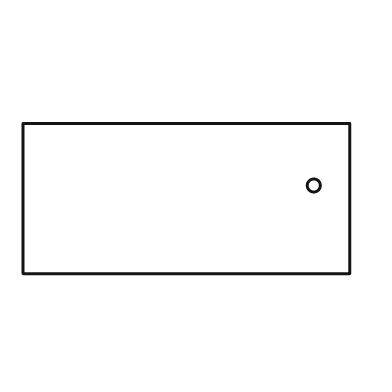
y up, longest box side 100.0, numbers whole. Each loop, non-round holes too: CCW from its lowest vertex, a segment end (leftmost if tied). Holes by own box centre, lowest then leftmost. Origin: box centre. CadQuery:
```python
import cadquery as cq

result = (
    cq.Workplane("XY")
    .moveTo(-50.0, -23.0)
    .lineTo(50.0, -23.0)
    .lineTo(50.0, 23.0)
    .lineTo(-50.0, 23.0)
    .close()
    .moveTo(39.0, 4.0)
    .circle(2.0)
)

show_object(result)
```